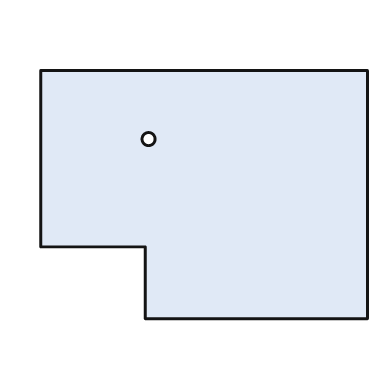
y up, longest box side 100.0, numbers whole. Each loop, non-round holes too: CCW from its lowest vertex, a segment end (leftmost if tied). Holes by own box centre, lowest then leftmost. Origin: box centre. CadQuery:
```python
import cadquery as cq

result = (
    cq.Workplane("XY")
    .moveTo(-18.0, -38.0)
    .lineTo(50.0, -38.0)
    .lineTo(50.0, 38.0)
    .lineTo(-50.0, 38.0)
    .lineTo(-50.0, -16.0)
    .lineTo(-18.0, -16.0)
    .close()
    .moveTo(-17.0, 17.0)
    .circle(2.0)
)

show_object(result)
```